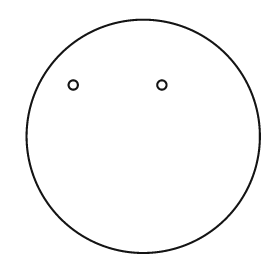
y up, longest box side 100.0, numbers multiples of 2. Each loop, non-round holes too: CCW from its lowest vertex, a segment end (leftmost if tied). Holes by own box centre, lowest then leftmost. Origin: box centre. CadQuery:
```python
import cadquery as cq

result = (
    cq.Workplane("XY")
    .moveTo(0.0, 0.0)
    .circle(50.0)
    .moveTo(-30.0, 22.0)
    .circle(2.0)
    .moveTo(8.0, 22.0)
    .circle(2.0)
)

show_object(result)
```